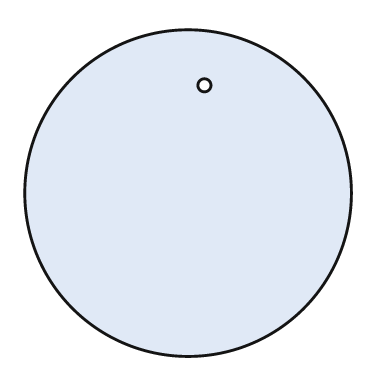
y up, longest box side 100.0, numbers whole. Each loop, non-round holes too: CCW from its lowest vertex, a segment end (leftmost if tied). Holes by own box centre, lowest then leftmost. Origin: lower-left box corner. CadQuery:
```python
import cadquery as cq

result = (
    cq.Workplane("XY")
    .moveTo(50.0, 50.0)
    .circle(50.0)
    .moveTo(55.0, 83.0)
    .circle(2.0)
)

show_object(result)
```